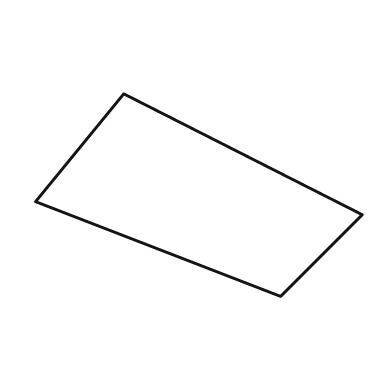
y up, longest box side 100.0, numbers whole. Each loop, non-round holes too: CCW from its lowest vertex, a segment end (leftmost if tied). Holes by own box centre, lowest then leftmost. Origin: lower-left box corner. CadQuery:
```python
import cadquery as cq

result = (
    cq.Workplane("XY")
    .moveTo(75.0, 0.0)
    .lineTo(100.0, 25.0)
    .lineTo(27.0, 62.0)
    .lineTo(0.0, 29.0)
    .close()
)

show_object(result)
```